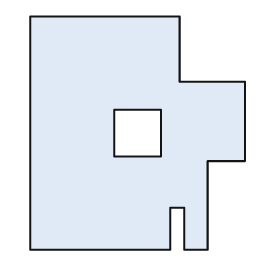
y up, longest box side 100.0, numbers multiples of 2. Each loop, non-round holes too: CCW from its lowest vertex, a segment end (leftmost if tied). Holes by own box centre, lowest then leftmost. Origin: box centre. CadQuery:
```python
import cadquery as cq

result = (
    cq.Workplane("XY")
    .moveTo(-46.0, -50.0)
    .lineTo(14.0, -50.0)
    .lineTo(14.0, -32.0)
    .lineTo(20.0, -32.0)
    .lineTo(20.0, -50.0)
    .lineTo(30.0, -50.0)
    .lineTo(30.0, -12.0)
    .lineTo(46.0, -12.0)
    .lineTo(46.0, 22.0)
    .lineTo(18.0, 22.0)
    .lineTo(18.0, 50.0)
    .lineTo(-46.0, 50.0)
    .close()
    .moveTo(-10.0, -10.0)
    .lineTo(10.0, -10.0)
    .lineTo(10.0, 10.0)
    .lineTo(-10.0, 10.0)
    .close()
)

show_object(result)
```